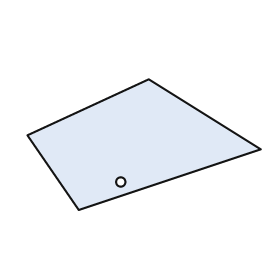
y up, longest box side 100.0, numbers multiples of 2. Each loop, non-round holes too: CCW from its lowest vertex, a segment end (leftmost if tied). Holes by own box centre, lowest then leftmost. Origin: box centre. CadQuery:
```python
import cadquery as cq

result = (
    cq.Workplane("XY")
    .moveTo(-28.0, -28.0)
    .lineTo(50.0, -2.0)
    .lineTo(2.0, 28.0)
    .lineTo(-50.0, 4.0)
    .close()
    .moveTo(-10.0, -16.0)
    .circle(2.0)
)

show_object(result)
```